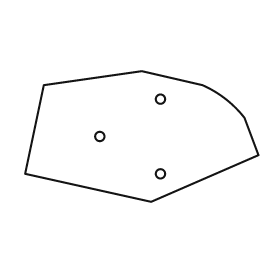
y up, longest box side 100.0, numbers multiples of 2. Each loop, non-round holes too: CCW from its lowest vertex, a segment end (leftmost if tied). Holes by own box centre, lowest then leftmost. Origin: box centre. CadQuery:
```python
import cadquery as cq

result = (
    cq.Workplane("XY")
    .moveTo(4.0, -28.0)
    .lineTo(50.0, -8.0)
    .lineTo(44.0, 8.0)
    .threePointArc((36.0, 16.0), (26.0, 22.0))
    .lineTo(0.0, 28.0)
    .lineTo(-42.0, 22.0)
    .lineTo(-50.0, -16.0)
    .close()
    .moveTo(8.0, -16.0)
    .circle(2.0)
    .moveTo(-18.0, 0.0)
    .circle(2.0)
    .moveTo(8.0, 16.0)
    .circle(2.0)
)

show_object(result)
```